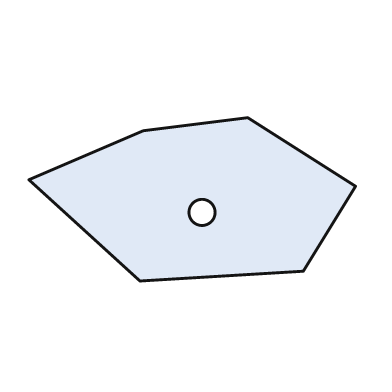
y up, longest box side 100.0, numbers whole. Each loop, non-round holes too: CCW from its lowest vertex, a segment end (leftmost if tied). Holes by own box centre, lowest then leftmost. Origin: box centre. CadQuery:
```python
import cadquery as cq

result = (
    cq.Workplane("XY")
    .moveTo(-16.0, -25.0)
    .lineTo(34.0, -22.0)
    .lineTo(50.0, 4.0)
    .lineTo(17.0, 25.0)
    .lineTo(-15.0, 21.0)
    .lineTo(-50.0, 6.0)
    .close()
    .moveTo(3.0, -4.0)
    .circle(4.0)
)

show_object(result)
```